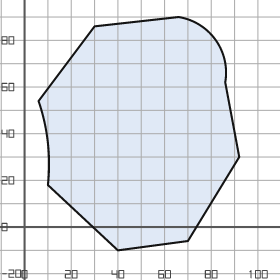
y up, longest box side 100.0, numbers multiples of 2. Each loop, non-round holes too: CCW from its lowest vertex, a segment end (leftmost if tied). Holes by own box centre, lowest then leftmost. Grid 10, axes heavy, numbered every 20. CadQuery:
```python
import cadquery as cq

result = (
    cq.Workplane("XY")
    .moveTo(40.0, -10.0)
    .lineTo(70.0, -6.0)
    .lineTo(92.0, 30.0)
    .lineTo(86.0, 62.0)
    .threePointArc((82.0, 80.0), (66.0, 90.0))
    .lineTo(30.0, 86.0)
    .lineTo(6.0, 54.0)
    .threePointArc((10.0, 36.0), (10.0, 18.0))
    .close()
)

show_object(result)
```